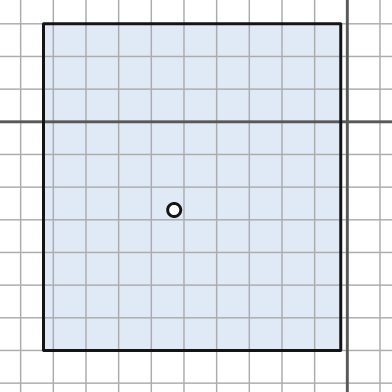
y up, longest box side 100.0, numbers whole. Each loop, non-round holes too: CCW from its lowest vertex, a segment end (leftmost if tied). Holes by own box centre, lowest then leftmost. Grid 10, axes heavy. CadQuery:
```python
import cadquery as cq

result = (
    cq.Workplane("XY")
    .moveTo(-93.0, -70.0)
    .lineTo(-2.0, -70.0)
    .lineTo(-2.0, 30.0)
    .lineTo(-93.0, 30.0)
    .close()
    .moveTo(-53.0, -27.0)
    .circle(2.0)
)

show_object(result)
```